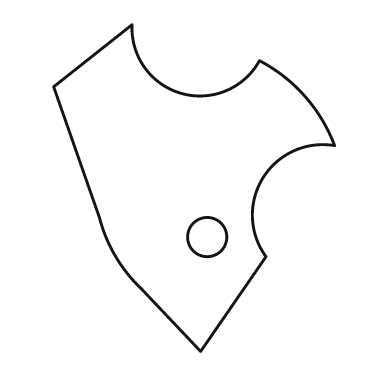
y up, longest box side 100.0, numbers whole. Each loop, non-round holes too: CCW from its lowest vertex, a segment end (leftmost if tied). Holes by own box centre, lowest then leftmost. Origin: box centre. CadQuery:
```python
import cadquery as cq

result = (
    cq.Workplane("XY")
    .moveTo(2.0, -50.0)
    .lineTo(22.0, -21.0)
    .threePointArc((21.0, 3.0), (43.0, 13.0))
    .threePointArc((34.0, 28.0), (20.0, 39.0))
    .threePointArc((-4.0, 29.0), (-19.0, 50.0))
    .lineTo(-43.0, 31.0)
    .lineTo(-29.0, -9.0)
    .threePointArc((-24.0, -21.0), (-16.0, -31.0))
    .close()
    .moveTo(4.0, -15.0)
    .circle(6.0)
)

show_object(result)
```